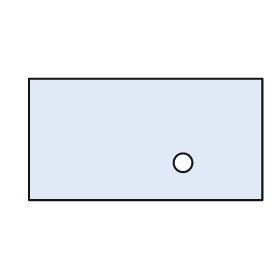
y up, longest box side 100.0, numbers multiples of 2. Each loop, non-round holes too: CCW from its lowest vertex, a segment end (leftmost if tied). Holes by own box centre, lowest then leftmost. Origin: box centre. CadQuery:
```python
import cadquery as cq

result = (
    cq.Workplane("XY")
    .moveTo(-50.0, -26.0)
    .lineTo(50.0, -26.0)
    .lineTo(50.0, 26.0)
    .lineTo(-50.0, 26.0)
    .close()
    .moveTo(16.0, -10.0)
    .circle(4.0)
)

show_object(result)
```